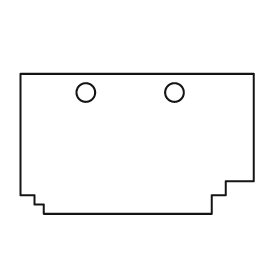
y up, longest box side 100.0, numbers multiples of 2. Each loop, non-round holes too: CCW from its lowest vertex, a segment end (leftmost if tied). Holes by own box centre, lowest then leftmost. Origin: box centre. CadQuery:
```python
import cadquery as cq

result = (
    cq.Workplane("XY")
    .moveTo(-40.0, -30.0)
    .lineTo(32.0, -30.0)
    .lineTo(32.0, -22.0)
    .lineTo(38.0, -22.0)
    .lineTo(38.0, -16.0)
    .lineTo(50.0, -16.0)
    .lineTo(50.0, 30.0)
    .lineTo(-50.0, 30.0)
    .lineTo(-50.0, -22.0)
    .lineTo(-44.0, -22.0)
    .lineTo(-44.0, -26.0)
    .lineTo(-40.0, -26.0)
    .close()
    .moveTo(-22.0, 22.0)
    .circle(4.0)
    .moveTo(16.0, 22.0)
    .circle(4.0)
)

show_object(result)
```